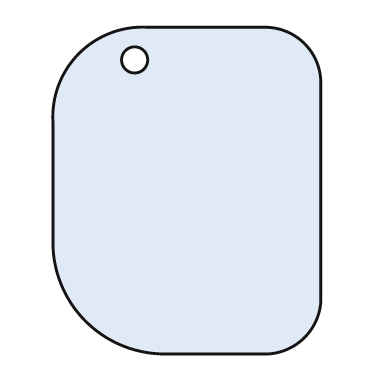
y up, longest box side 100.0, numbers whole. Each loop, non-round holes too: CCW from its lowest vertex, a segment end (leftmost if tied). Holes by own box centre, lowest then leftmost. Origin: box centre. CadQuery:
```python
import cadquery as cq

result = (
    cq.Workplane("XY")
    .moveTo(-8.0, -50.0)
    .lineTo(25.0, -50.0)
    .threePointArc((36.0, -45.0), (41.0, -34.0))
    .lineTo(41.0, 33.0)
    .threePointArc((36.0, 45.0), (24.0, 50.0))
    .lineTo(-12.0, 50.0)
    .threePointArc((-33.0, 42.0), (-41.0, 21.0))
    .lineTo(-41.0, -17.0)
    .threePointArc((-31.0, -40.0), (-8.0, -50.0))
    .close()
    .moveTo(-16.0, 40.0)
    .circle(4.0)
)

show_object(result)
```